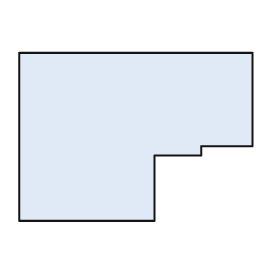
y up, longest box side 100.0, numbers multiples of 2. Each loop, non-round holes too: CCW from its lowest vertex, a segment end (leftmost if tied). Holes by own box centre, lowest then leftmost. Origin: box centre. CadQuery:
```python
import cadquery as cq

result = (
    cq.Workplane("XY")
    .moveTo(-50.0, -36.0)
    .lineTo(8.0, -36.0)
    .lineTo(8.0, -8.0)
    .lineTo(28.0, -8.0)
    .lineTo(28.0, -4.0)
    .lineTo(50.0, -4.0)
    .lineTo(50.0, 36.0)
    .lineTo(-50.0, 36.0)
    .close()
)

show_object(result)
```